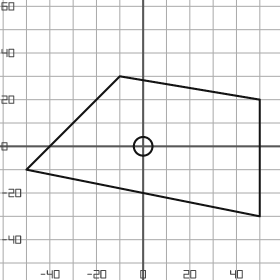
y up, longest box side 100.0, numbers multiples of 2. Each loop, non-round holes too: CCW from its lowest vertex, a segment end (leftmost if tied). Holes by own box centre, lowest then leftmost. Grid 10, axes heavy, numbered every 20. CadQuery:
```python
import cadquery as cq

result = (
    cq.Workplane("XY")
    .moveTo(50.0, -30.0)
    .lineTo(50.0, 20.0)
    .lineTo(-10.0, 30.0)
    .lineTo(-50.0, -10.0)
    .close()
    .moveTo(0.0, 0.0)
    .circle(4.0)
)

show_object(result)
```